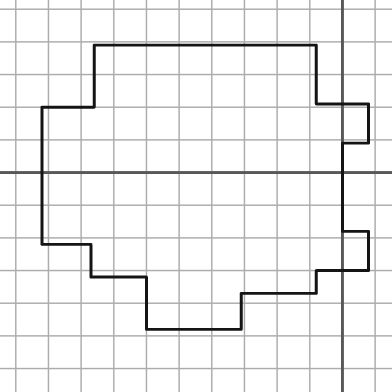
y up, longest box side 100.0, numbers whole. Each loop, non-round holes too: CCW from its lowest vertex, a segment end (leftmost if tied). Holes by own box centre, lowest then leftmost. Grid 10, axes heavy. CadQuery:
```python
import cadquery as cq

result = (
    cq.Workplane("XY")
    .moveTo(-60.0, -48.0)
    .lineTo(-31.0, -48.0)
    .lineTo(-31.0, -37.0)
    .lineTo(-8.0, -37.0)
    .lineTo(-8.0, -30.0)
    .lineTo(8.0, -30.0)
    .lineTo(8.0, -18.0)
    .lineTo(0.0, -18.0)
    .lineTo(0.0, 9.0)
    .lineTo(8.0, 9.0)
    .lineTo(8.0, 21.0)
    .lineTo(-8.0, 21.0)
    .lineTo(-8.0, 39.0)
    .lineTo(-76.0, 39.0)
    .lineTo(-76.0, 20.0)
    .lineTo(-92.0, 20.0)
    .lineTo(-92.0, -22.0)
    .lineTo(-77.0, -22.0)
    .lineTo(-77.0, -32.0)
    .lineTo(-60.0, -32.0)
    .close()
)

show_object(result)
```